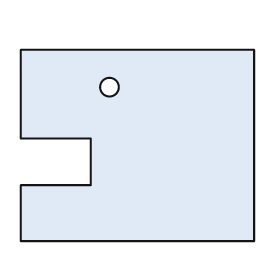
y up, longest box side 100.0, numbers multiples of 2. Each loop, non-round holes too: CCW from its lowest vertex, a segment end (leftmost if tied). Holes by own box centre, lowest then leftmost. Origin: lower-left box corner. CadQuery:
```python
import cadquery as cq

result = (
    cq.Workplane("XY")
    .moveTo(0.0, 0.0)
    .lineTo(100.0, 0.0)
    .lineTo(100.0, 82.0)
    .lineTo(0.0, 82.0)
    .lineTo(0.0, 44.0)
    .lineTo(30.0, 44.0)
    .lineTo(30.0, 24.0)
    .lineTo(0.0, 24.0)
    .close()
    .moveTo(38.0, 66.0)
    .circle(4.0)
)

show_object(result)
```